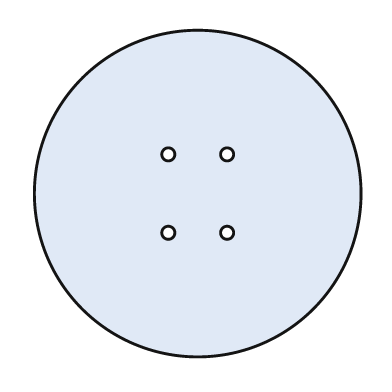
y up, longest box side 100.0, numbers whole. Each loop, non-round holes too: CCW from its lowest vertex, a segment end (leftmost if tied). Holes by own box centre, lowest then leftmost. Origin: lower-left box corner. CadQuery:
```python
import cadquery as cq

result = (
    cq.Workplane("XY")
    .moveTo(50.0, 50.0)
    .circle(50.0)
    .moveTo(41.0, 38.0)
    .circle(2.0)
    .moveTo(59.0, 38.0)
    .circle(2.0)
    .moveTo(41.0, 62.0)
    .circle(2.0)
    .moveTo(59.0, 62.0)
    .circle(2.0)
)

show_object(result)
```